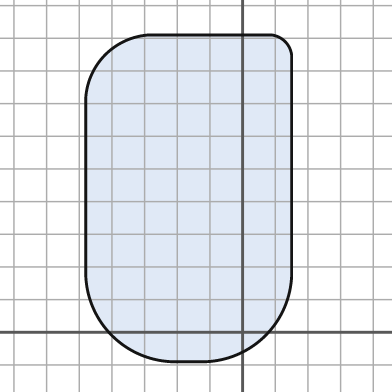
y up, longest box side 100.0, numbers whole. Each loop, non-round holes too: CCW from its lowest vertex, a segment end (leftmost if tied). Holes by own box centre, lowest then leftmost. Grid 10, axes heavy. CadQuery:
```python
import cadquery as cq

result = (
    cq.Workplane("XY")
    .moveTo(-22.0, -9.0)
    .lineTo(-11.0, -9.0)
    .threePointArc((7.0, -1.0), (15.0, 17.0))
    .lineTo(15.0, 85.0)
    .threePointArc((13.0, 89.0), (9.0, 91.0))
    .lineTo(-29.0, 91.0)
    .threePointArc((-42.0, 85.0), (-48.0, 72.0))
    .lineTo(-48.0, 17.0)
    .threePointArc((-40.0, -1.0), (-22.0, -9.0))
    .close()
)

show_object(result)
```